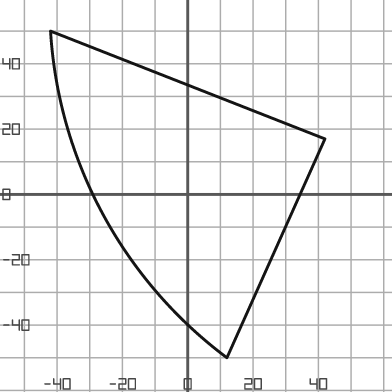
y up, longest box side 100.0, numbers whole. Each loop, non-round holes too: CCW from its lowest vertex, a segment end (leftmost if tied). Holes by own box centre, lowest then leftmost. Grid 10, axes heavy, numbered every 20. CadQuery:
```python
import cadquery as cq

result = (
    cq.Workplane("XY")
    .moveTo(12.0, -50.0)
    .lineTo(42.0, 17.0)
    .lineTo(-42.0, 50.0)
    .threePointArc((-26.0, -6.0), (12.0, -50.0))
    .close()
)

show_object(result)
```